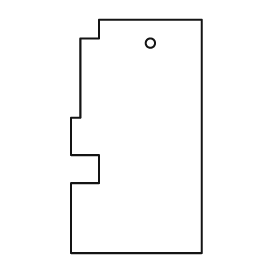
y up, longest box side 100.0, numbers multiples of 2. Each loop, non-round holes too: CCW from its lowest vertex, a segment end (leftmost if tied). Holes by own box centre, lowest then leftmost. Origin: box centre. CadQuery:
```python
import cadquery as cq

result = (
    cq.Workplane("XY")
    .moveTo(-28.0, -50.0)
    .lineTo(28.0, -50.0)
    .lineTo(28.0, 50.0)
    .lineTo(-16.0, 50.0)
    .lineTo(-16.0, 42.0)
    .lineTo(-24.0, 42.0)
    .lineTo(-24.0, 8.0)
    .lineTo(-28.0, 8.0)
    .lineTo(-28.0, -8.0)
    .lineTo(-16.0, -8.0)
    .lineTo(-16.0, -20.0)
    .lineTo(-28.0, -20.0)
    .close()
    .moveTo(6.0, 40.0)
    .circle(2.0)
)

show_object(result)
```